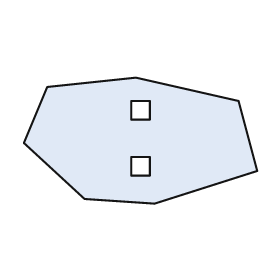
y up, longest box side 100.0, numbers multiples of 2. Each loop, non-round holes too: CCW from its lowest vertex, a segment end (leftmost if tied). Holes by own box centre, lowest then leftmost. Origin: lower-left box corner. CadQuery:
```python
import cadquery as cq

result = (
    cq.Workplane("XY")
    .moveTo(56.0, 0.0)
    .lineTo(100.0, 14.0)
    .lineTo(92.0, 44.0)
    .lineTo(48.0, 54.0)
    .lineTo(10.0, 50.0)
    .lineTo(0.0, 26.0)
    .lineTo(26.0, 2.0)
    .close()
    .moveTo(46.0, 12.0)
    .lineTo(54.0, 12.0)
    .lineTo(54.0, 20.0)
    .lineTo(46.0, 20.0)
    .close()
    .moveTo(46.0, 36.0)
    .lineTo(54.0, 36.0)
    .lineTo(54.0, 44.0)
    .lineTo(46.0, 44.0)
    .close()
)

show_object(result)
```